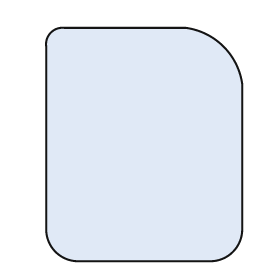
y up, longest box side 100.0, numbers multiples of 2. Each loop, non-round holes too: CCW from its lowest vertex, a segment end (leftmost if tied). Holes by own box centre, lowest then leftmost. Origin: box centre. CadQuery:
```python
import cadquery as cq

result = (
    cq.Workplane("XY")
    .moveTo(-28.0, -50.0)
    .lineTo(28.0, -50.0)
    .threePointArc((38.0, -46.0), (42.0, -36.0))
    .lineTo(42.0, 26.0)
    .threePointArc((34.0, 42.0), (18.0, 50.0))
    .lineTo(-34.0, 50.0)
    .threePointArc((-40.0, 48.0), (-42.0, 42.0))
    .lineTo(-42.0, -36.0)
    .threePointArc((-38.0, -46.0), (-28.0, -50.0))
    .close()
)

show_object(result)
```